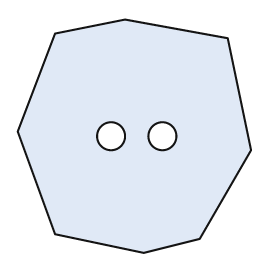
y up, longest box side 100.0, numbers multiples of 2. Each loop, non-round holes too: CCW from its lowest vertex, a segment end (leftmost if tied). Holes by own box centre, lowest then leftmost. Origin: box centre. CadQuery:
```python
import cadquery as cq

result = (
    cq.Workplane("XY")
    .moveTo(4.0, -50.0)
    .lineTo(28.0, -44.0)
    .lineTo(50.0, -6.0)
    .lineTo(40.0, 42.0)
    .lineTo(-4.0, 50.0)
    .lineTo(-34.0, 44.0)
    .lineTo(-50.0, 2.0)
    .lineTo(-34.0, -42.0)
    .close()
    .moveTo(-10.0, 0.0)
    .circle(6.0)
    .moveTo(12.0, 0.0)
    .circle(6.0)
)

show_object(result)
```